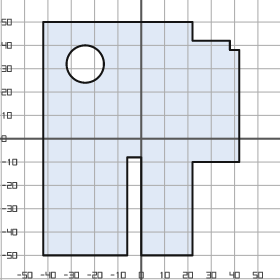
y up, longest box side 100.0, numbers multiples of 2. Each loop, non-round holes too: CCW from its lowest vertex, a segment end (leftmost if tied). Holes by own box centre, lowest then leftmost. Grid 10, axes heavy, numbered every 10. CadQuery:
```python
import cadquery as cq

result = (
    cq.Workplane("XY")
    .moveTo(-42.0, -50.0)
    .lineTo(-6.0, -50.0)
    .lineTo(-6.0, -8.0)
    .lineTo(0.0, -8.0)
    .lineTo(0.0, -50.0)
    .lineTo(22.0, -50.0)
    .lineTo(22.0, -10.0)
    .lineTo(42.0, -10.0)
    .lineTo(42.0, 38.0)
    .lineTo(38.0, 38.0)
    .lineTo(38.0, 42.0)
    .lineTo(22.0, 42.0)
    .lineTo(22.0, 50.0)
    .lineTo(-42.0, 50.0)
    .close()
    .moveTo(-24.0, 32.0)
    .circle(8.0)
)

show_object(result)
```